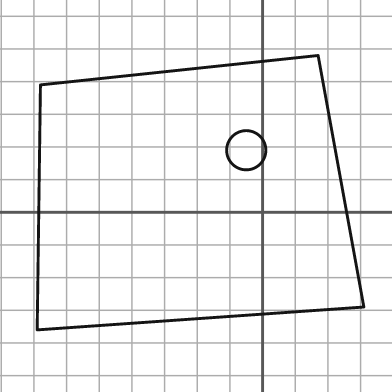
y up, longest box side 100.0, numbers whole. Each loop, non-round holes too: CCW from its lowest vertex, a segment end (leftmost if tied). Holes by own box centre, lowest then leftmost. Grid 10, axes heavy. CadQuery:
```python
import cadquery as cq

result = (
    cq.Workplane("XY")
    .moveTo(-69.0, -36.0)
    .lineTo(31.0, -29.0)
    .lineTo(17.0, 48.0)
    .lineTo(-68.0, 39.0)
    .close()
    .moveTo(-5.0, 19.0)
    .circle(6.0)
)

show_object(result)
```